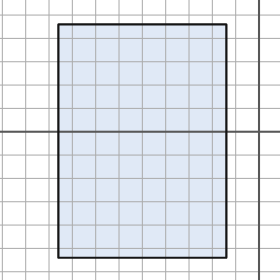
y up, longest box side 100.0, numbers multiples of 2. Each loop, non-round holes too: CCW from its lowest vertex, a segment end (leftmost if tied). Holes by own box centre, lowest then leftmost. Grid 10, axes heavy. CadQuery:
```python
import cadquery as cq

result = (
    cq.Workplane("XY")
    .moveTo(-86.0, -54.0)
    .lineTo(-14.0, -54.0)
    .lineTo(-14.0, 46.0)
    .lineTo(-86.0, 46.0)
    .close()
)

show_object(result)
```